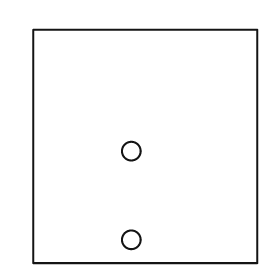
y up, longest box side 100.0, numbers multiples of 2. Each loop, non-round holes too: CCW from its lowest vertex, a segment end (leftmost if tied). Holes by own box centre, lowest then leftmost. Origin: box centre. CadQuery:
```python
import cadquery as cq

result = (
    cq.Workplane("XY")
    .moveTo(-48.0, -50.0)
    .lineTo(48.0, -50.0)
    .lineTo(48.0, 50.0)
    .lineTo(-48.0, 50.0)
    .close()
    .moveTo(-6.0, -40.0)
    .circle(4.0)
    .moveTo(-6.0, -2.0)
    .circle(4.0)
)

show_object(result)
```